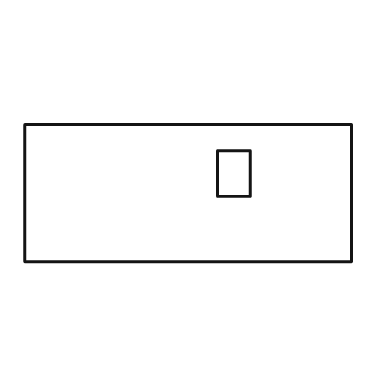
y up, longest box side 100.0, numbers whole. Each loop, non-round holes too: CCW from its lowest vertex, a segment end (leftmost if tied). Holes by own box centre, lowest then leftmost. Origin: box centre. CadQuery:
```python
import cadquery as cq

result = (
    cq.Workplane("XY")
    .moveTo(-50.0, -21.0)
    .lineTo(50.0, -21.0)
    .lineTo(50.0, 21.0)
    .lineTo(-50.0, 21.0)
    .close()
    .moveTo(9.0, -1.0)
    .lineTo(19.0, -1.0)
    .lineTo(19.0, 13.0)
    .lineTo(9.0, 13.0)
    .close()
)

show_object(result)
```